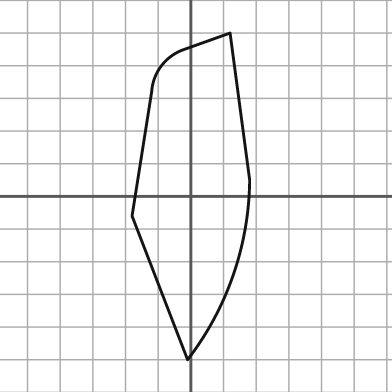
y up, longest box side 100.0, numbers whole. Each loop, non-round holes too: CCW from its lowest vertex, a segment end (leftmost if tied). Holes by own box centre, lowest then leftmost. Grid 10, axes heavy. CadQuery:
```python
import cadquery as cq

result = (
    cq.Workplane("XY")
    .moveTo(-1.0, -50.0)
    .threePointArc((13.0, -24.0), (18.0, 5.0))
    .lineTo(12.0, 50.0)
    .lineTo(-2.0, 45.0)
    .threePointArc((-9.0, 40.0), (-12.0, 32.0))
    .lineTo(-18.0, -6.0)
    .close()
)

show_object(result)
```